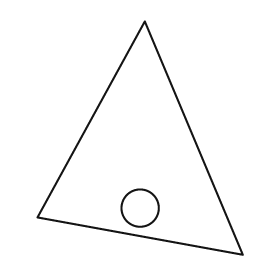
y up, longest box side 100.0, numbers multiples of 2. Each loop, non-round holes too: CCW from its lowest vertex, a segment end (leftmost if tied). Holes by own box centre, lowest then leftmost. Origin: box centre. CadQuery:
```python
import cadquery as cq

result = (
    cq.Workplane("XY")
    .moveTo(44.0, -50.0)
    .lineTo(2.0, 50.0)
    .lineTo(-44.0, -34.0)
    .close()
    .moveTo(0.0, -30.0)
    .circle(8.0)
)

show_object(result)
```